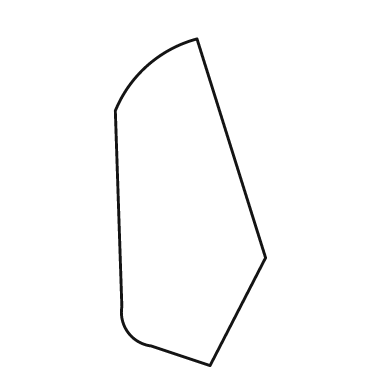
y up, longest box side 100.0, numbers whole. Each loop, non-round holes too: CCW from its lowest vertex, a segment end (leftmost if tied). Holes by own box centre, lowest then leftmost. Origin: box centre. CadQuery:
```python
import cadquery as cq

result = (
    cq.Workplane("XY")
    .moveTo(6.0, -50.0)
    .lineTo(23.0, -17.0)
    .lineTo(2.0, 50.0)
    .threePointArc((-13.0, 42.0), (-23.0, 28.0))
    .lineTo(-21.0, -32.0)
    .threePointArc((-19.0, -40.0), (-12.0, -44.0))
    .close()
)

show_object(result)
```